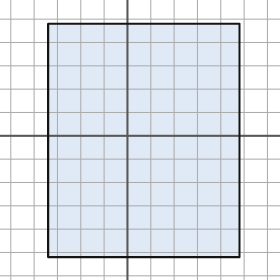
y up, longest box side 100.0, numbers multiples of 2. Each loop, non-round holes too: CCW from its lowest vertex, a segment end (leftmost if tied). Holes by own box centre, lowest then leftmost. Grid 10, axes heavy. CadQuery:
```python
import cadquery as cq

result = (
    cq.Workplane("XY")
    .moveTo(-34.0, -52.0)
    .lineTo(48.0, -52.0)
    .lineTo(48.0, 48.0)
    .lineTo(-34.0, 48.0)
    .close()
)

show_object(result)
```